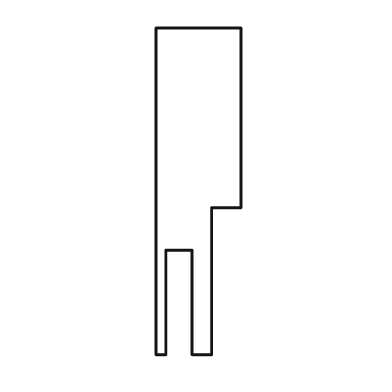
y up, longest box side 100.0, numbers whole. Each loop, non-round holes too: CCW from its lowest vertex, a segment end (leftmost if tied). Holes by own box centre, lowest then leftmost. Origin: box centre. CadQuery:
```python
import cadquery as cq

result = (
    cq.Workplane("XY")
    .moveTo(-13.0, -50.0)
    .lineTo(-10.0, -50.0)
    .lineTo(-10.0, -18.0)
    .lineTo(-2.0, -18.0)
    .lineTo(-2.0, -50.0)
    .lineTo(4.0, -50.0)
    .lineTo(4.0, -5.0)
    .lineTo(13.0, -5.0)
    .lineTo(13.0, 50.0)
    .lineTo(-13.0, 50.0)
    .close()
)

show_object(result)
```